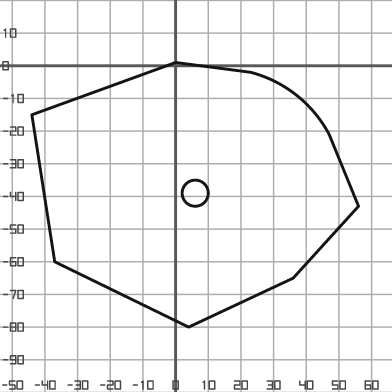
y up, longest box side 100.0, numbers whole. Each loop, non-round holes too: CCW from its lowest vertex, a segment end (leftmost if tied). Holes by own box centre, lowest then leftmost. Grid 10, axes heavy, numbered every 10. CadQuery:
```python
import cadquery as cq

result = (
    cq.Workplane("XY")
    .moveTo(4.0, -80.0)
    .lineTo(36.0, -65.0)
    .lineTo(56.0, -43.0)
    .lineTo(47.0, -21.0)
    .threePointArc((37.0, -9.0), (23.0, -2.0))
    .lineTo(0.0, 1.0)
    .lineTo(-44.0, -15.0)
    .lineTo(-37.0, -60.0)
    .close()
    .moveTo(6.0, -39.0)
    .circle(4.0)
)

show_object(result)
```